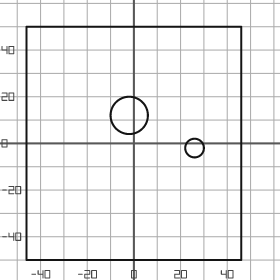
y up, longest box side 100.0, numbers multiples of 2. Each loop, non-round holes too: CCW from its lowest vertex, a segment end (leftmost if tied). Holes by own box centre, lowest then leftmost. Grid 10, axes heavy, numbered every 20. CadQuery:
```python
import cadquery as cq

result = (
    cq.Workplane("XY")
    .moveTo(-46.0, -50.0)
    .lineTo(46.0, -50.0)
    .lineTo(46.0, 50.0)
    .lineTo(-46.0, 50.0)
    .close()
    .moveTo(26.0, -2.0)
    .circle(4.0)
    .moveTo(-2.0, 12.0)
    .circle(8.0)
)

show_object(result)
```